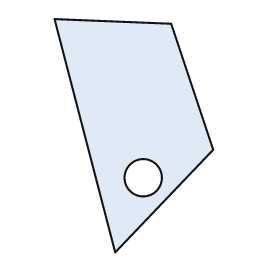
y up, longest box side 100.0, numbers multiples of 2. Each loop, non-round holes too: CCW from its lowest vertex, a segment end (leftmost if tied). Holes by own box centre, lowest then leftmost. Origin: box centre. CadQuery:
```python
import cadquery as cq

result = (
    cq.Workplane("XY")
    .moveTo(-8.0, -50.0)
    .lineTo(34.0, -6.0)
    .lineTo(16.0, 48.0)
    .lineTo(-34.0, 50.0)
    .close()
    .moveTo(4.0, -18.0)
    .circle(8.0)
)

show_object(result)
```